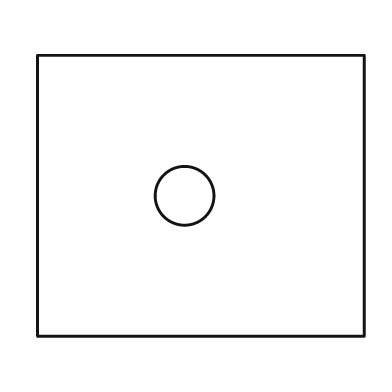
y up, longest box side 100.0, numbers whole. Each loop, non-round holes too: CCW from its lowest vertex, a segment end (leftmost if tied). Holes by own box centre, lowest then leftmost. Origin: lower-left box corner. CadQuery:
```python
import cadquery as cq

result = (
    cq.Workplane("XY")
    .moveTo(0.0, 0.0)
    .lineTo(100.0, 0.0)
    .lineTo(100.0, 86.0)
    .lineTo(0.0, 86.0)
    .close()
    .moveTo(45.0, 43.0)
    .circle(9.0)
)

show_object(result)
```